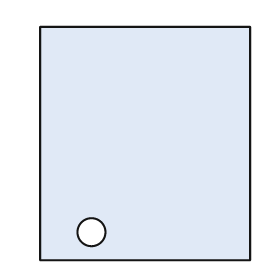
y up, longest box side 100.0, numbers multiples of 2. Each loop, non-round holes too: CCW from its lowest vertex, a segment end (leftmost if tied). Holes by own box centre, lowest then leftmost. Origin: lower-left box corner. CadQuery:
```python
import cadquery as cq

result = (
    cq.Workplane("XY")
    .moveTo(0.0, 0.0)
    .lineTo(90.0, 0.0)
    .lineTo(90.0, 100.0)
    .lineTo(0.0, 100.0)
    .close()
    .moveTo(22.0, 12.0)
    .circle(6.0)
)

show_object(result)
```